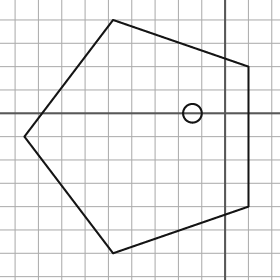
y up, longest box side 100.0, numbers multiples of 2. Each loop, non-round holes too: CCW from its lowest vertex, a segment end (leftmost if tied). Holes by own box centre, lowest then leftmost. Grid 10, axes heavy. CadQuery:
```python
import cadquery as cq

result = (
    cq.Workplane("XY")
    .moveTo(-48.0, -60.0)
    .lineTo(10.0, -40.0)
    .lineTo(10.0, 20.0)
    .lineTo(-48.0, 40.0)
    .lineTo(-86.0, -10.0)
    .close()
    .moveTo(-14.0, 0.0)
    .circle(4.0)
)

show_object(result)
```